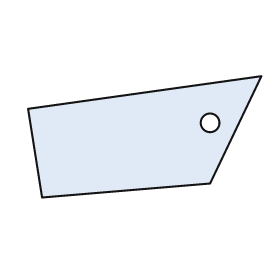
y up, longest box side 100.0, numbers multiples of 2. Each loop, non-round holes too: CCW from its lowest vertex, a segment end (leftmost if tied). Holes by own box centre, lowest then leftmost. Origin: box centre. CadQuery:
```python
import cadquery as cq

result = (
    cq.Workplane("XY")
    .moveTo(-44.0, -26.0)
    .lineTo(28.0, -20.0)
    .lineTo(50.0, 26.0)
    .lineTo(-50.0, 12.0)
    .close()
    .moveTo(28.0, 6.0)
    .circle(4.0)
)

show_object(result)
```